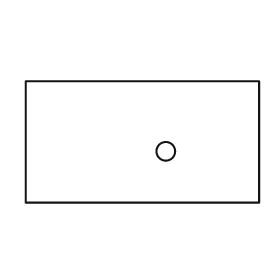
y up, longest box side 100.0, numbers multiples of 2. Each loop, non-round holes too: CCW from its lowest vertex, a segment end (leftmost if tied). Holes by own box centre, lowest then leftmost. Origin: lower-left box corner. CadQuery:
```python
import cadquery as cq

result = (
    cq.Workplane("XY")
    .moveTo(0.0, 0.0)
    .lineTo(100.0, 0.0)
    .lineTo(100.0, 52.0)
    .lineTo(0.0, 52.0)
    .close()
    .moveTo(60.0, 22.0)
    .circle(4.0)
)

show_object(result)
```